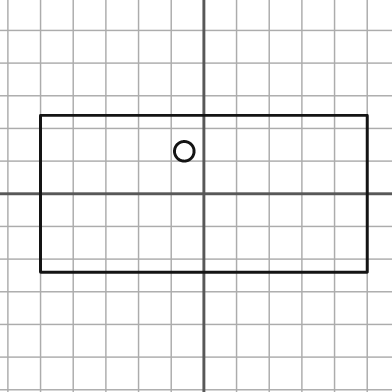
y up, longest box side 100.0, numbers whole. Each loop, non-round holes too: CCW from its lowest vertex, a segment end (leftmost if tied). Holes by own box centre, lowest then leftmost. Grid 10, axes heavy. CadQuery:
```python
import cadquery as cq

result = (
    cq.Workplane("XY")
    .moveTo(-50.0, -24.0)
    .lineTo(50.0, -24.0)
    .lineTo(50.0, 24.0)
    .lineTo(-50.0, 24.0)
    .close()
    .moveTo(-6.0, 13.0)
    .circle(3.0)
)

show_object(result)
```